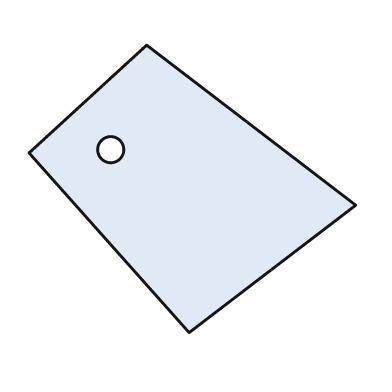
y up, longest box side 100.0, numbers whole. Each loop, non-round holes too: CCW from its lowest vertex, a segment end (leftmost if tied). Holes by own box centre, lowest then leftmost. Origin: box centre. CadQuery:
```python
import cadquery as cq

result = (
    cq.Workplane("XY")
    .moveTo(-1.0, -44.0)
    .lineTo(50.0, -5.0)
    .lineTo(-14.0, 44.0)
    .lineTo(-50.0, 11.0)
    .close()
    .moveTo(-25.0, 12.0)
    .circle(4.0)
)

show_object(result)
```